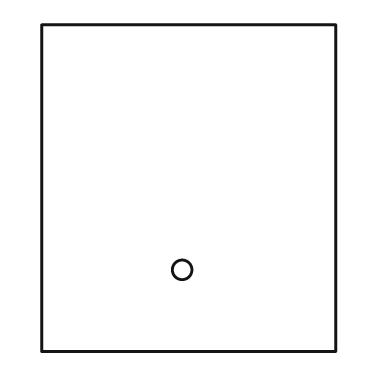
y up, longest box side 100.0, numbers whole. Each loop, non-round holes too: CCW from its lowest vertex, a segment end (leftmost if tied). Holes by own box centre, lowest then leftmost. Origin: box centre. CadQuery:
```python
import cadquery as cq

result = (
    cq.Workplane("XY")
    .moveTo(-45.0, -50.0)
    .lineTo(45.0, -50.0)
    .lineTo(45.0, 50.0)
    .lineTo(-45.0, 50.0)
    .close()
    .moveTo(-2.0, -25.0)
    .circle(3.0)
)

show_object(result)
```